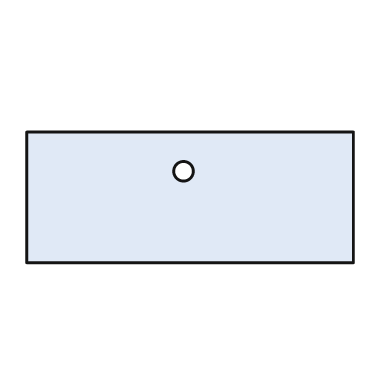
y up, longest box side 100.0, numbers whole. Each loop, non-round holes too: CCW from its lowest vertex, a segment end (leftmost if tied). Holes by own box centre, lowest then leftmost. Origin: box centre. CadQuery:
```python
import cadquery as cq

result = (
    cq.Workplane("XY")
    .moveTo(-50.0, -20.0)
    .lineTo(50.0, -20.0)
    .lineTo(50.0, 20.0)
    .lineTo(-50.0, 20.0)
    .close()
    .moveTo(-2.0, 8.0)
    .circle(3.0)
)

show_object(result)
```